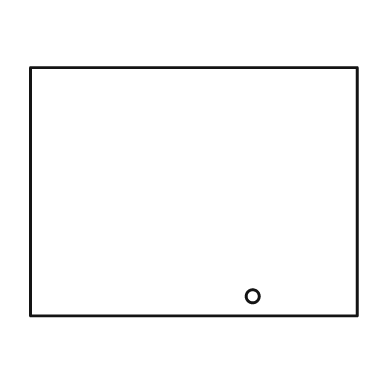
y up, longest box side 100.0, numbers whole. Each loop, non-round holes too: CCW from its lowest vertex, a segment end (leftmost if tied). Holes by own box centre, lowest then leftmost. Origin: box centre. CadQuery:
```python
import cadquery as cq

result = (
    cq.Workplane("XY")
    .moveTo(-50.0, -38.0)
    .lineTo(50.0, -38.0)
    .lineTo(50.0, 38.0)
    .lineTo(-50.0, 38.0)
    .close()
    .moveTo(18.0, -32.0)
    .circle(2.0)
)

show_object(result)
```